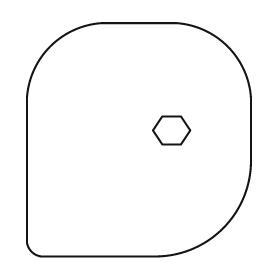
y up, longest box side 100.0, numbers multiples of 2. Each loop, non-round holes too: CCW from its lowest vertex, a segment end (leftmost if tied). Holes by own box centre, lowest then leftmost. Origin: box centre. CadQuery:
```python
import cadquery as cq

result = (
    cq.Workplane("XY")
    .moveTo(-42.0, -50.0)
    .lineTo(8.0, -50.0)
    .threePointArc((36.0, -38.0), (48.0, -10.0))
    .lineTo(48.0, 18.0)
    .threePointArc((38.0, 40.0), (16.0, 50.0))
    .lineTo(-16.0, 50.0)
    .threePointArc((-38.0, 40.0), (-48.0, 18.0))
    .lineTo(-48.0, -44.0)
    .threePointArc((-46.0, -48.0), (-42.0, -50.0))
    .close()
    .moveTo(10.0, -2.0)
    .lineTo(18.0, -2.0)
    .lineTo(22.0, 4.0)
    .lineTo(18.0, 10.0)
    .lineTo(10.0, 10.0)
    .lineTo(6.0, 4.0)
    .close()
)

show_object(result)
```